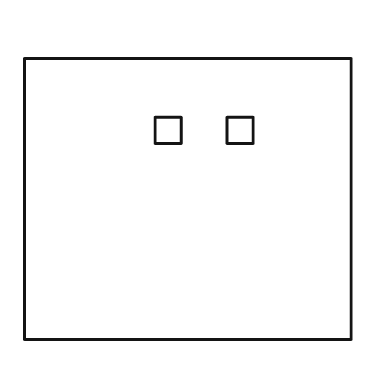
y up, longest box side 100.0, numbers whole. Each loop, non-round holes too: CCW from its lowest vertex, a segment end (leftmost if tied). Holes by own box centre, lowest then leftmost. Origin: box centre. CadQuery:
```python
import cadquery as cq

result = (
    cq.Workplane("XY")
    .moveTo(-50.0, -43.0)
    .lineTo(50.0, -43.0)
    .lineTo(50.0, 43.0)
    .lineTo(-50.0, 43.0)
    .close()
    .moveTo(-10.0, 17.0)
    .lineTo(-2.0, 17.0)
    .lineTo(-2.0, 25.0)
    .lineTo(-10.0, 25.0)
    .close()
    .moveTo(12.0, 17.0)
    .lineTo(20.0, 17.0)
    .lineTo(20.0, 25.0)
    .lineTo(12.0, 25.0)
    .close()
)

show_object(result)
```